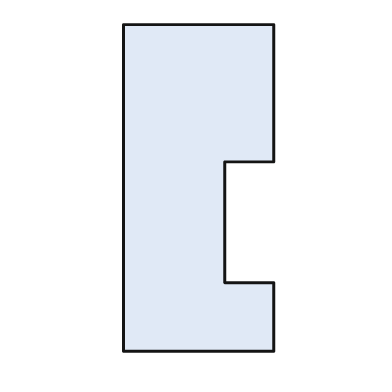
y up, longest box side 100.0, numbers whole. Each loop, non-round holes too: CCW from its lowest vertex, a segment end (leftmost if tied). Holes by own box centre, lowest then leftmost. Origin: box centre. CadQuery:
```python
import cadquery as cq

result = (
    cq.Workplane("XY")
    .moveTo(-23.0, -50.0)
    .lineTo(23.0, -50.0)
    .lineTo(23.0, -29.0)
    .lineTo(8.0, -29.0)
    .lineTo(8.0, 8.0)
    .lineTo(23.0, 8.0)
    .lineTo(23.0, 50.0)
    .lineTo(-23.0, 50.0)
    .close()
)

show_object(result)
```